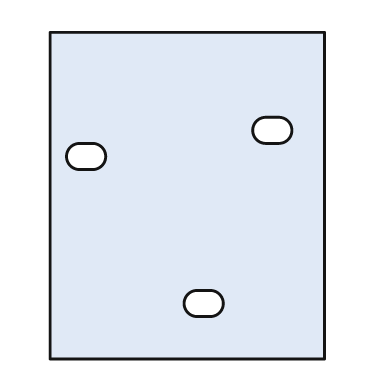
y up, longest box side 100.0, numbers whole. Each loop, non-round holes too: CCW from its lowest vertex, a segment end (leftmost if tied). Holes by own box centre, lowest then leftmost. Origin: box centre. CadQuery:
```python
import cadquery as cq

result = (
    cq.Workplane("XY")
    .moveTo(-42.0, -50.0)
    .lineTo(42.0, -50.0)
    .lineTo(42.0, 50.0)
    .lineTo(-42.0, 50.0)
    .close()
    .moveTo(3.0, -37.0)
    .lineTo(7.0, -37.0)
    .threePointArc((11.0, -33.0), (7.0, -29.0))
    .lineTo(3.0, -29.0)
    .threePointArc((-1.0, -33.0), (3.0, -37.0))
    .close()
    .moveTo(-33.0, 8.0)
    .lineTo(-29.0, 8.0)
    .threePointArc((-25.0, 12.0), (-29.0, 16.0))
    .lineTo(-33.0, 16.0)
    .threePointArc((-37.0, 12.0), (-33.0, 8.0))
    .close()
    .moveTo(24.0, 16.0)
    .lineTo(28.0, 16.0)
    .threePointArc((32.0, 20.0), (28.0, 24.0))
    .lineTo(24.0, 24.0)
    .threePointArc((20.0, 20.0), (24.0, 16.0))
    .close()
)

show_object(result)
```